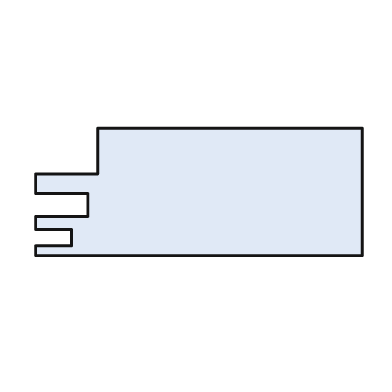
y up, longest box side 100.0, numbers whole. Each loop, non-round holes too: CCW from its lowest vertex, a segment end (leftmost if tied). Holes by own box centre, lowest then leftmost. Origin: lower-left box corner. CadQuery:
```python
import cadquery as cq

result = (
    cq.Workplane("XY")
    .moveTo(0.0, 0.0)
    .lineTo(100.0, 0.0)
    .lineTo(100.0, 39.0)
    .lineTo(19.0, 39.0)
    .lineTo(19.0, 25.0)
    .lineTo(0.0, 25.0)
    .lineTo(0.0, 19.0)
    .lineTo(16.0, 19.0)
    .lineTo(16.0, 12.0)
    .lineTo(0.0, 12.0)
    .lineTo(0.0, 8.0)
    .lineTo(11.0, 8.0)
    .lineTo(11.0, 3.0)
    .lineTo(0.0, 3.0)
    .close()
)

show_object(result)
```